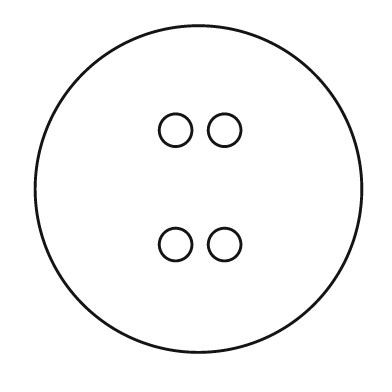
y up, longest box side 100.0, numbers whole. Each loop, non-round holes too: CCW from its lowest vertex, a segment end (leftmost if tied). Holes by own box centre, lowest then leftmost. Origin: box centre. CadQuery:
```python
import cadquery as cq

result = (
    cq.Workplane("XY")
    .moveTo(0.0, 0.0)
    .circle(50.0)
    .moveTo(-7.0, -17.0)
    .circle(5.0)
    .moveTo(8.0, -17.0)
    .circle(5.0)
    .moveTo(-7.0, 18.0)
    .circle(5.0)
    .moveTo(8.0, 18.0)
    .circle(5.0)
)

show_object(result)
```